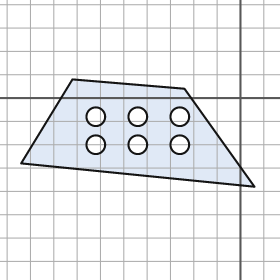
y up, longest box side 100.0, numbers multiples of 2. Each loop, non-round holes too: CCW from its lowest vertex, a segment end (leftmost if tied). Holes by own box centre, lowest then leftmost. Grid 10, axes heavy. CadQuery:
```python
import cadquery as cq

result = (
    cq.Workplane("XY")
    .moveTo(6.0, -38.0)
    .lineTo(-24.0, 4.0)
    .lineTo(-72.0, 8.0)
    .lineTo(-94.0, -28.0)
    .close()
    .moveTo(-62.0, -20.0)
    .circle(4.0)
    .moveTo(-44.0, -20.0)
    .circle(4.0)
    .moveTo(-26.0, -20.0)
    .circle(4.0)
    .moveTo(-62.0, -8.0)
    .circle(4.0)
    .moveTo(-44.0, -8.0)
    .circle(4.0)
    .moveTo(-26.0, -8.0)
    .circle(4.0)
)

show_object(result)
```